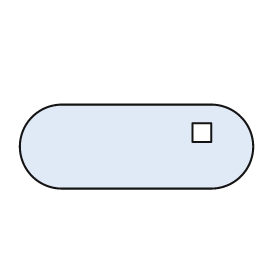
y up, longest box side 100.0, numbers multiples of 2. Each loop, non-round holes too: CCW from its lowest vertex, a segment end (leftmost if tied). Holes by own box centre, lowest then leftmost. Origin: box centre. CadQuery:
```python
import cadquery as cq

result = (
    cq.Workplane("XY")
    .moveTo(-32.0, -18.0)
    .lineTo(32.0, -18.0)
    .threePointArc((50.0, 0.0), (32.0, 18.0))
    .lineTo(-32.0, 18.0)
    .threePointArc((-50.0, 0.0), (-32.0, -18.0))
    .close()
    .moveTo(24.0, 2.0)
    .lineTo(32.0, 2.0)
    .lineTo(32.0, 10.0)
    .lineTo(24.0, 10.0)
    .close()
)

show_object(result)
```